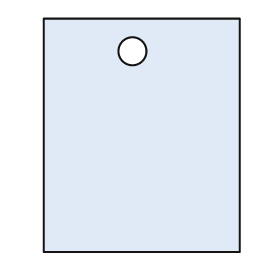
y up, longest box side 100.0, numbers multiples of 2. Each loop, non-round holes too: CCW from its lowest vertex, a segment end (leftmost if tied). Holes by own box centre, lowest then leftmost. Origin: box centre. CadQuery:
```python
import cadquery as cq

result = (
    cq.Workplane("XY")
    .moveTo(-42.0, -50.0)
    .lineTo(42.0, -50.0)
    .lineTo(42.0, 50.0)
    .lineTo(-42.0, 50.0)
    .close()
    .moveTo(-4.0, 36.0)
    .circle(6.0)
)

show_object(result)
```